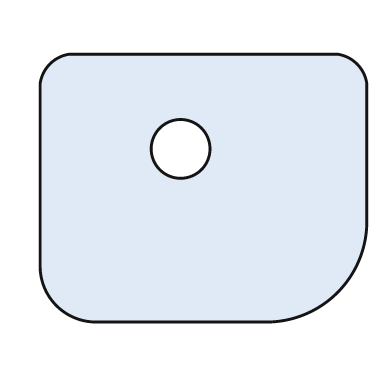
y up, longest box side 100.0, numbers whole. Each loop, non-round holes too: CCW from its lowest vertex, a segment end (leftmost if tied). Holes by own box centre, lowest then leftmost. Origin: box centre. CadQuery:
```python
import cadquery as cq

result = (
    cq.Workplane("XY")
    .moveTo(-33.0, -41.0)
    .lineTo(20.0, -41.0)
    .threePointArc((41.0, -32.0), (50.0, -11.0))
    .lineTo(50.0, 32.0)
    .threePointArc((47.0, 38.0), (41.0, 41.0))
    .lineTo(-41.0, 41.0)
    .threePointArc((-47.0, 38.0), (-50.0, 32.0))
    .lineTo(-50.0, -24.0)
    .threePointArc((-45.0, -36.0), (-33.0, -41.0))
    .close()
    .moveTo(-7.0, 12.0)
    .circle(9.0)
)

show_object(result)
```